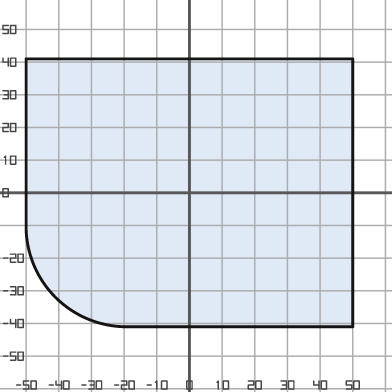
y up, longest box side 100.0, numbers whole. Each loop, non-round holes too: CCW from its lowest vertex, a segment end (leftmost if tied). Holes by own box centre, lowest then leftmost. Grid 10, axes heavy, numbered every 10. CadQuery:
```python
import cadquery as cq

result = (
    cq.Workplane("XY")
    .moveTo(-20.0, -41.0)
    .lineTo(50.0, -41.0)
    .lineTo(50.0, 41.0)
    .lineTo(-50.0, 41.0)
    .lineTo(-50.0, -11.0)
    .threePointArc((-41.0, -32.0), (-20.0, -41.0))
    .close()
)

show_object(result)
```